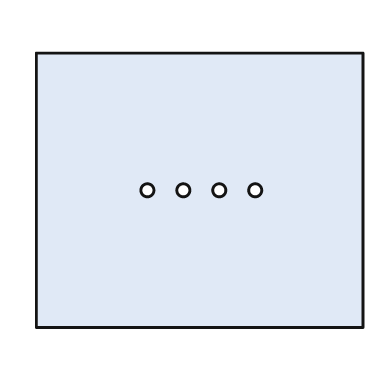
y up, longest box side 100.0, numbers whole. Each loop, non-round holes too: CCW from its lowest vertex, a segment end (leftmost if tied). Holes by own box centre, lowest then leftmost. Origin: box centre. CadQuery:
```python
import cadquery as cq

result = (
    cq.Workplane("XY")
    .moveTo(-50.0, -42.0)
    .lineTo(50.0, -42.0)
    .lineTo(50.0, 42.0)
    .lineTo(-50.0, 42.0)
    .close()
    .moveTo(-16.0, 0.0)
    .circle(2.0)
    .moveTo(-5.0, 0.0)
    .circle(2.0)
    .moveTo(6.0, 0.0)
    .circle(2.0)
    .moveTo(17.0, 0.0)
    .circle(2.0)
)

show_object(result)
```